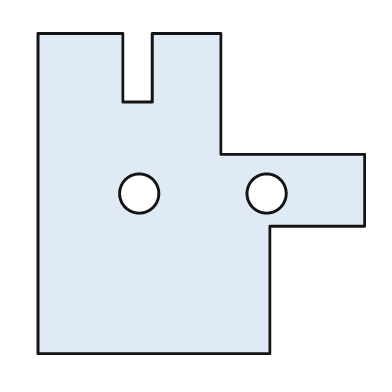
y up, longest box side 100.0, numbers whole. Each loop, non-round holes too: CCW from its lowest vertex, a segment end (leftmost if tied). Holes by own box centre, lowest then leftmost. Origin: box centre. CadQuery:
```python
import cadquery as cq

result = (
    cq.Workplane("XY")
    .moveTo(-50.0, -49.0)
    .lineTo(21.0, -49.0)
    .lineTo(21.0, -10.0)
    .lineTo(50.0, -10.0)
    .lineTo(50.0, 12.0)
    .lineTo(6.0, 12.0)
    .lineTo(6.0, 49.0)
    .lineTo(-15.0, 49.0)
    .lineTo(-15.0, 28.0)
    .lineTo(-24.0, 28.0)
    .lineTo(-24.0, 49.0)
    .lineTo(-50.0, 49.0)
    .close()
    .moveTo(-19.0, 0.0)
    .circle(6.0)
    .moveTo(20.0, 0.0)
    .circle(6.0)
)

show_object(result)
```